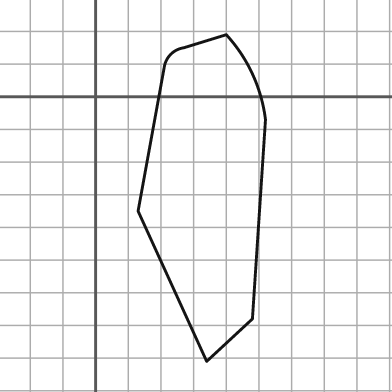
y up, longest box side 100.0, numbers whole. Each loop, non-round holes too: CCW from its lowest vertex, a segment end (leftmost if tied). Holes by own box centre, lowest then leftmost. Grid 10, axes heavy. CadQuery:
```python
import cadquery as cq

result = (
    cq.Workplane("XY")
    .moveTo(34.0, -81.0)
    .lineTo(48.0, -68.0)
    .lineTo(52.0, -7.0)
    .threePointArc((48.0, 7.0), (40.0, 19.0))
    .lineTo(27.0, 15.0)
    .threePointArc((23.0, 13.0), (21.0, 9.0))
    .lineTo(13.0, -35.0)
    .close()
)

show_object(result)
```